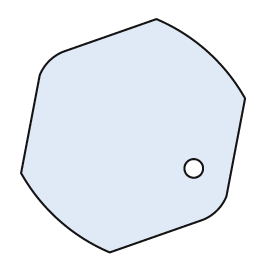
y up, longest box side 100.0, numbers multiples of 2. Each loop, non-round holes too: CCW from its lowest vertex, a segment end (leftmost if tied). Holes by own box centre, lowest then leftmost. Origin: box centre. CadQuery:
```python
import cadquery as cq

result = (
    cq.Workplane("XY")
    .moveTo(-10.0, -50.0)
    .lineTo(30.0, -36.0)
    .threePointArc((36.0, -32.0), (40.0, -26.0))
    .lineTo(48.0, 16.0)
    .threePointArc((32.0, 36.0), (10.0, 50.0))
    .lineTo(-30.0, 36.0)
    .threePointArc((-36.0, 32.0), (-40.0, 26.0))
    .lineTo(-48.0, -16.0)
    .threePointArc((-32.0, -36.0), (-10.0, -50.0))
    .close()
    .moveTo(26.0, -14.0)
    .circle(4.0)
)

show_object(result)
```